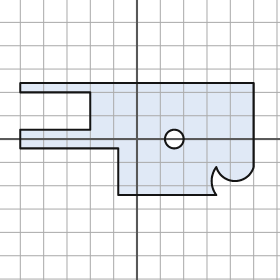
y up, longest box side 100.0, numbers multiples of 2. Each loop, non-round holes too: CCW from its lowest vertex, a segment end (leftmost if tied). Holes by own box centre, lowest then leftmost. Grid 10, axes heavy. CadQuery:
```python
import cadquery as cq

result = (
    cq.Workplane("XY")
    .moveTo(-8.0, -24.0)
    .lineTo(34.0, -24.0)
    .threePointArc((32.0, -18.0), (34.0, -12.0))
    .threePointArc((42.0, -18.0), (50.0, -12.0))
    .lineTo(50.0, 24.0)
    .lineTo(-50.0, 24.0)
    .lineTo(-50.0, 20.0)
    .lineTo(-20.0, 20.0)
    .lineTo(-20.0, 4.0)
    .lineTo(-50.0, 4.0)
    .lineTo(-50.0, -4.0)
    .lineTo(-8.0, -4.0)
    .close()
    .moveTo(16.0, 0.0)
    .circle(4.0)
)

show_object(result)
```